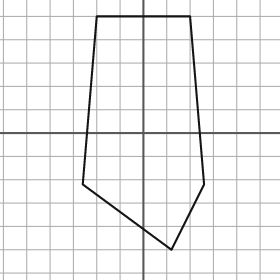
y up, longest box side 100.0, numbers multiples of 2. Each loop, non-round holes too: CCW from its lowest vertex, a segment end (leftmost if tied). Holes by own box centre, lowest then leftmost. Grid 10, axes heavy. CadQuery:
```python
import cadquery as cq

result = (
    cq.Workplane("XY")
    .moveTo(12.0, -50.0)
    .lineTo(26.0, -22.0)
    .lineTo(20.0, 50.0)
    .lineTo(-20.0, 50.0)
    .lineTo(-26.0, -22.0)
    .close()
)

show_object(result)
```